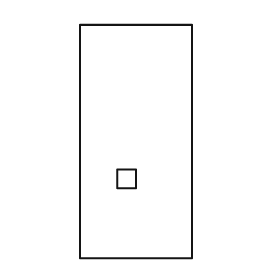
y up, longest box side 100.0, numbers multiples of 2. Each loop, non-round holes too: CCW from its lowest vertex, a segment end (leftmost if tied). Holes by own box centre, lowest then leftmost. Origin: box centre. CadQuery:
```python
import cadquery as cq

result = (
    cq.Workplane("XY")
    .moveTo(-24.0, -50.0)
    .lineTo(24.0, -50.0)
    .lineTo(24.0, 50.0)
    .lineTo(-24.0, 50.0)
    .close()
    .moveTo(-8.0, -20.0)
    .lineTo(0.0, -20.0)
    .lineTo(0.0, -12.0)
    .lineTo(-8.0, -12.0)
    .close()
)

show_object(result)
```